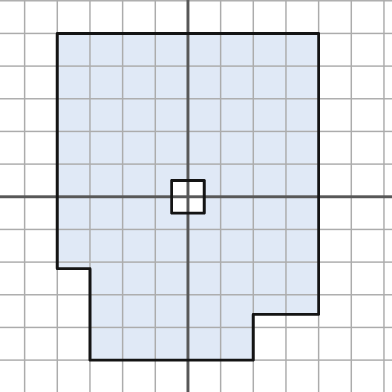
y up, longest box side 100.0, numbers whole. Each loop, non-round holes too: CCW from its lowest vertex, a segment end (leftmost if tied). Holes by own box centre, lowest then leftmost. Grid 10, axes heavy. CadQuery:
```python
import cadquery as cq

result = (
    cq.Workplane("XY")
    .moveTo(-30.0, -50.0)
    .lineTo(20.0, -50.0)
    .lineTo(20.0, -36.0)
    .lineTo(40.0, -36.0)
    .lineTo(40.0, 50.0)
    .lineTo(-40.0, 50.0)
    .lineTo(-40.0, -22.0)
    .lineTo(-30.0, -22.0)
    .close()
    .moveTo(-5.0, -5.0)
    .lineTo(5.0, -5.0)
    .lineTo(5.0, 5.0)
    .lineTo(-5.0, 5.0)
    .close()
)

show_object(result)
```